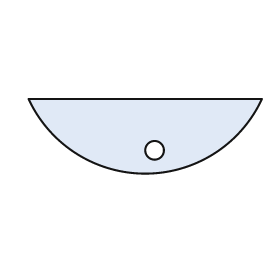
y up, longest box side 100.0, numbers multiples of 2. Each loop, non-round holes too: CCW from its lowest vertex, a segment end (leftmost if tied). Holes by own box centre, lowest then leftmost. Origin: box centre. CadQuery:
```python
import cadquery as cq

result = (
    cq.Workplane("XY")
    .moveTo(-50.0, 16.0)
    .threePointArc((0.0, -16.0), (50.0, 16.0))
    .close()
    .moveTo(4.0, -6.0)
    .circle(4.0)
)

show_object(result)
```